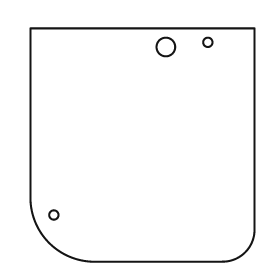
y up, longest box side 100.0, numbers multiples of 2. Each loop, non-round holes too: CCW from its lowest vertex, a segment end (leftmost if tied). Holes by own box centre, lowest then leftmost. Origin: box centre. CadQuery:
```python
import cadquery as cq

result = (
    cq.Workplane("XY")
    .moveTo(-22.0, -50.0)
    .lineTo(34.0, -50.0)
    .threePointArc((44.0, -46.0), (48.0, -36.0))
    .lineTo(48.0, 50.0)
    .lineTo(-48.0, 50.0)
    .lineTo(-48.0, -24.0)
    .threePointArc((-40.0, -42.0), (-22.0, -50.0))
    .close()
    .moveTo(-38.0, -30.0)
    .circle(2.0)
    .moveTo(10.0, 42.0)
    .circle(4.0)
    .moveTo(28.0, 44.0)
    .circle(2.0)
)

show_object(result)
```